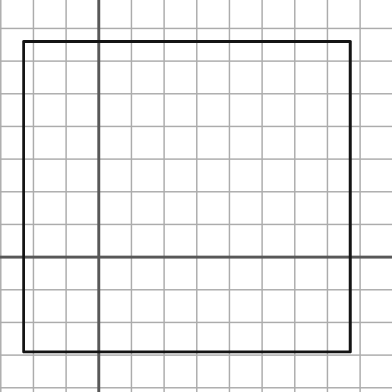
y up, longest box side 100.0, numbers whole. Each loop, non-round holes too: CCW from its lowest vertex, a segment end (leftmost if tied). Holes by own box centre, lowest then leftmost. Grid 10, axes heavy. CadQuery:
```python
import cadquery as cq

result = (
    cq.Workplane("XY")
    .moveTo(-23.0, -29.0)
    .lineTo(77.0, -29.0)
    .lineTo(77.0, 66.0)
    .lineTo(-23.0, 66.0)
    .close()
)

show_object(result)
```